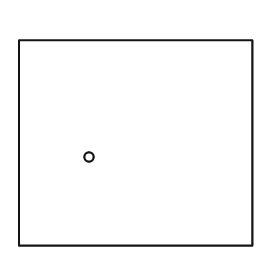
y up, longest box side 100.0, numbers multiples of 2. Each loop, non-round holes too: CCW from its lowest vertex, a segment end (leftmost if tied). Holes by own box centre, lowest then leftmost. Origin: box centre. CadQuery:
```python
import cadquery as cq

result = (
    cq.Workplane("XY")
    .moveTo(-50.0, -44.0)
    .lineTo(50.0, -44.0)
    .lineTo(50.0, 44.0)
    .lineTo(-50.0, 44.0)
    .close()
    .moveTo(-20.0, -6.0)
    .circle(2.0)
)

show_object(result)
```